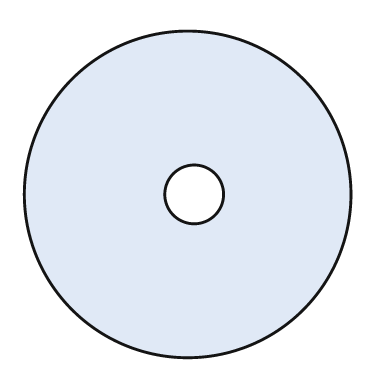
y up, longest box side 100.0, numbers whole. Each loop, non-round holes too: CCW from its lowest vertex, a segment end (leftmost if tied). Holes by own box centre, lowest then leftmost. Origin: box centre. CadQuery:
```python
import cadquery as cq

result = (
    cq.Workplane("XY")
    .moveTo(0.0, 0.0)
    .circle(50.0)
    .moveTo(2.0, 0.0)
    .circle(9.0)
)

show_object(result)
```